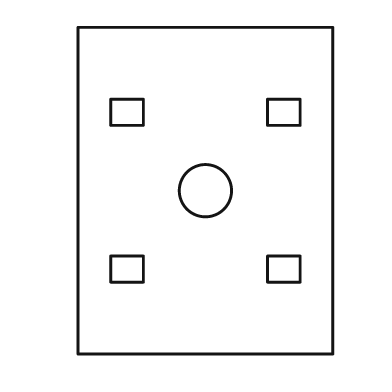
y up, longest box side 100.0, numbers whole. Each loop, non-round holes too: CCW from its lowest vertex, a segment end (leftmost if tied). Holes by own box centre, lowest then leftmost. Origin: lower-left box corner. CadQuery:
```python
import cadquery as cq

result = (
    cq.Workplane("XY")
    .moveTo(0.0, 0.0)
    .lineTo(78.0, 0.0)
    .lineTo(78.0, 100.0)
    .lineTo(0.0, 100.0)
    .close()
    .moveTo(10.0, 22.0)
    .lineTo(20.0, 22.0)
    .lineTo(20.0, 30.0)
    .lineTo(10.0, 30.0)
    .close()
    .moveTo(58.0, 22.0)
    .lineTo(68.0, 22.0)
    .lineTo(68.0, 30.0)
    .lineTo(58.0, 30.0)
    .close()
    .moveTo(39.0, 50.0)
    .circle(8.0)
    .moveTo(10.0, 70.0)
    .lineTo(20.0, 70.0)
    .lineTo(20.0, 78.0)
    .lineTo(10.0, 78.0)
    .close()
    .moveTo(58.0, 70.0)
    .lineTo(68.0, 70.0)
    .lineTo(68.0, 78.0)
    .lineTo(58.0, 78.0)
    .close()
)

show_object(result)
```